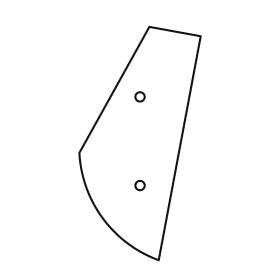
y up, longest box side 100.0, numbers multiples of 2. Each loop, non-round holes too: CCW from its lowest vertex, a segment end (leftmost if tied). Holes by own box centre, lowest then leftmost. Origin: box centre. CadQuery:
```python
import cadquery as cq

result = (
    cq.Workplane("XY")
    .moveTo(8.0, -50.0)
    .lineTo(26.0, 46.0)
    .lineTo(4.0, 50.0)
    .lineTo(-26.0, -4.0)
    .threePointArc((-16.0, -32.0), (8.0, -50.0))
    .close()
    .moveTo(0.0, -18.0)
    .circle(2.0)
    .moveTo(0.0, 20.0)
    .circle(2.0)
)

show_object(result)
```